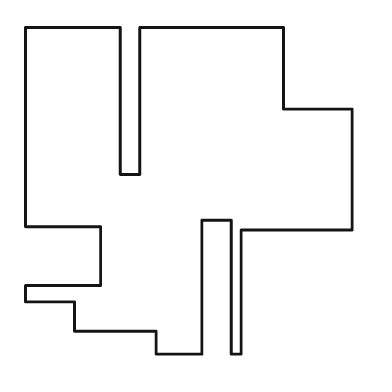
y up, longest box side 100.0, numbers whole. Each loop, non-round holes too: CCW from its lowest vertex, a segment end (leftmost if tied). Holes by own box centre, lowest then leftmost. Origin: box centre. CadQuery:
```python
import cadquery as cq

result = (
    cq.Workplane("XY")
    .moveTo(-10.0, -50.0)
    .lineTo(4.0, -50.0)
    .lineTo(4.0, -9.0)
    .lineTo(13.0, -9.0)
    .lineTo(13.0, -50.0)
    .lineTo(16.0, -50.0)
    .lineTo(16.0, -12.0)
    .lineTo(50.0, -12.0)
    .lineTo(50.0, 25.0)
    .lineTo(29.0, 25.0)
    .lineTo(29.0, 50.0)
    .lineTo(-15.0, 50.0)
    .lineTo(-15.0, 5.0)
    .lineTo(-21.0, 5.0)
    .lineTo(-21.0, 50.0)
    .lineTo(-50.0, 50.0)
    .lineTo(-50.0, -11.0)
    .lineTo(-27.0, -11.0)
    .lineTo(-27.0, -29.0)
    .lineTo(-50.0, -29.0)
    .lineTo(-50.0, -34.0)
    .lineTo(-35.0, -34.0)
    .lineTo(-35.0, -43.0)
    .lineTo(-10.0, -43.0)
    .close()
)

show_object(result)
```